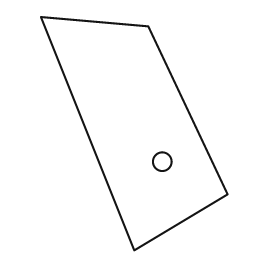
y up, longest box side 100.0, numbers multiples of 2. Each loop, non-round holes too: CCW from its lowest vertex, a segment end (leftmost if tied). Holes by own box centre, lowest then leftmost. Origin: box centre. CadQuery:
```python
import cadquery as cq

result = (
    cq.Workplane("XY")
    .moveTo(0.0, -50.0)
    .lineTo(40.0, -26.0)
    .lineTo(6.0, 46.0)
    .lineTo(-40.0, 50.0)
    .close()
    .moveTo(12.0, -12.0)
    .circle(4.0)
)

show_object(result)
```